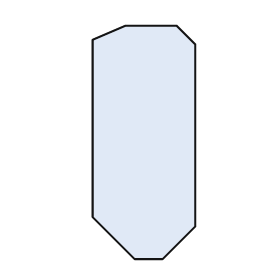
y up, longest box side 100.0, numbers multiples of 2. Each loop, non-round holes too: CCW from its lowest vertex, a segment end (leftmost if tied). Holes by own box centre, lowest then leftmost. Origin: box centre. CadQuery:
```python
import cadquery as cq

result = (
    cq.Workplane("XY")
    .moveTo(-4.0, -50.0)
    .lineTo(8.0, -50.0)
    .lineTo(22.0, -36.0)
    .lineTo(22.0, 42.0)
    .lineTo(14.0, 50.0)
    .lineTo(-8.0, 50.0)
    .lineTo(-22.0, 44.0)
    .lineTo(-22.0, -32.0)
    .close()
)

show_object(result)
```